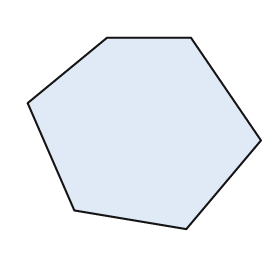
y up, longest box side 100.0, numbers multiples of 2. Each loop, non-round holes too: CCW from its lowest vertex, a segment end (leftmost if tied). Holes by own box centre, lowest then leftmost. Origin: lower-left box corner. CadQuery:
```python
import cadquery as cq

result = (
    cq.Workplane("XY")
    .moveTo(68.0, 0.0)
    .lineTo(100.0, 38.0)
    .lineTo(70.0, 82.0)
    .lineTo(34.0, 82.0)
    .lineTo(0.0, 54.0)
    .lineTo(20.0, 8.0)
    .close()
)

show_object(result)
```